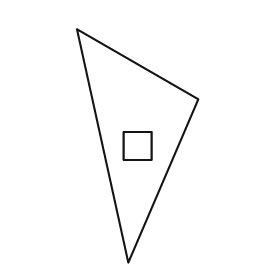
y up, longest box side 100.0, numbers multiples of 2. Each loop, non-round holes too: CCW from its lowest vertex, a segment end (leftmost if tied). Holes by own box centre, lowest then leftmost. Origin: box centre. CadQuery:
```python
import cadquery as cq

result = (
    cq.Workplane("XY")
    .moveTo(-4.0, -50.0)
    .lineTo(26.0, 20.0)
    .lineTo(-26.0, 50.0)
    .close()
    .moveTo(-6.0, -6.0)
    .lineTo(6.0, -6.0)
    .lineTo(6.0, 6.0)
    .lineTo(-6.0, 6.0)
    .close()
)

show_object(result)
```